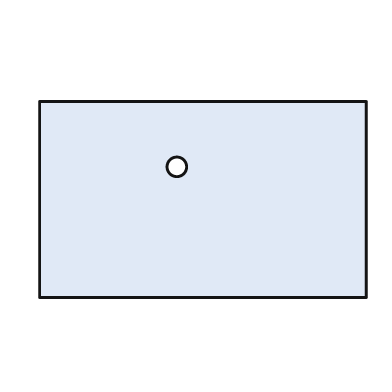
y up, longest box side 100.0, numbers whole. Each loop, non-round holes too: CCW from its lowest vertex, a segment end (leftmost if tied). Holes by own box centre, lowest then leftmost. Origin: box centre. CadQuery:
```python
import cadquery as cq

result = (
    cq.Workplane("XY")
    .moveTo(-50.0, -30.0)
    .lineTo(50.0, -30.0)
    .lineTo(50.0, 30.0)
    .lineTo(-50.0, 30.0)
    .close()
    .moveTo(-8.0, 10.0)
    .circle(3.0)
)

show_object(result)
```